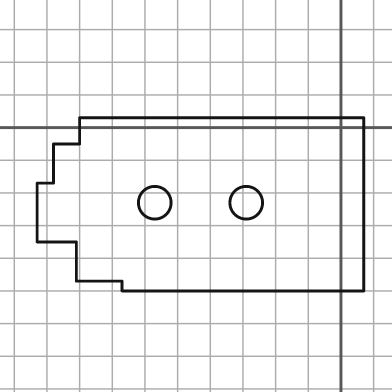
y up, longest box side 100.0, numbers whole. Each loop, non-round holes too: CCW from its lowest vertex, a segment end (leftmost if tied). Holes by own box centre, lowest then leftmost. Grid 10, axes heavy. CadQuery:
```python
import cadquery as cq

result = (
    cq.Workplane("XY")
    .moveTo(-67.0, -50.0)
    .lineTo(7.0, -50.0)
    .lineTo(7.0, 3.0)
    .lineTo(-80.0, 3.0)
    .lineTo(-80.0, -5.0)
    .lineTo(-88.0, -5.0)
    .lineTo(-88.0, -17.0)
    .lineTo(-93.0, -17.0)
    .lineTo(-93.0, -35.0)
    .lineTo(-81.0, -35.0)
    .lineTo(-81.0, -47.0)
    .lineTo(-67.0, -47.0)
    .close()
    .moveTo(-57.0, -23.0)
    .circle(5.0)
    .moveTo(-29.0, -23.0)
    .circle(5.0)
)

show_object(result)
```